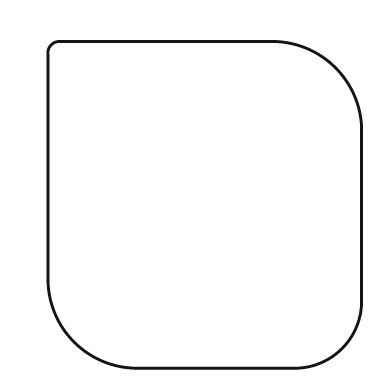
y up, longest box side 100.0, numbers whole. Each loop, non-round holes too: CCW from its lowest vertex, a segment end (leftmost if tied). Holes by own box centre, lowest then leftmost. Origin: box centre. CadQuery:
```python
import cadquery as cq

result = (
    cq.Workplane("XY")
    .moveTo(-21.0, -50.0)
    .lineTo(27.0, -50.0)
    .threePointArc((42.0, -44.0), (48.0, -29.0))
    .lineTo(48.0, 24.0)
    .threePointArc((40.0, 42.0), (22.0, 50.0))
    .lineTo(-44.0, 50.0)
    .threePointArc((-47.0, 49.0), (-48.0, 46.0))
    .lineTo(-48.0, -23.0)
    .threePointArc((-40.0, -42.0), (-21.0, -50.0))
    .close()
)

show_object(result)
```